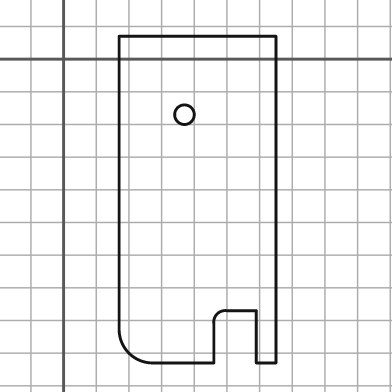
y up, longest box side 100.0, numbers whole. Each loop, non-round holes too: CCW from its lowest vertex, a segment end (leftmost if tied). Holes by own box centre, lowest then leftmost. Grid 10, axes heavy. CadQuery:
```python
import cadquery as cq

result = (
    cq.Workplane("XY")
    .moveTo(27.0, -93.0)
    .lineTo(46.0, -93.0)
    .lineTo(46.0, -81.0)
    .threePointArc((47.0, -78.0), (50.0, -77.0))
    .lineTo(59.0, -77.0)
    .lineTo(59.0, -93.0)
    .lineTo(65.0, -93.0)
    .lineTo(65.0, 7.0)
    .lineTo(17.0, 7.0)
    .lineTo(17.0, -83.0)
    .threePointArc((20.0, -90.0), (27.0, -93.0))
    .close()
    .moveTo(37.0, -17.0)
    .circle(3.0)
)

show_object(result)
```